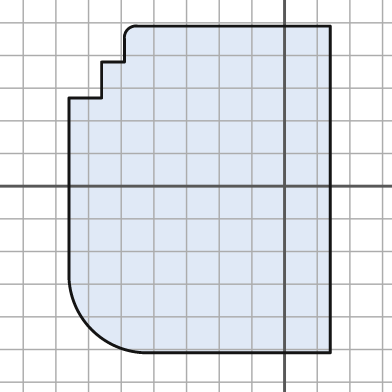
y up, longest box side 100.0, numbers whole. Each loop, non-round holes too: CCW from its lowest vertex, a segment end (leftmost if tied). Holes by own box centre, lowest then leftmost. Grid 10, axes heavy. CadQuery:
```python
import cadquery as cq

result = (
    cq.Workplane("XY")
    .moveTo(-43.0, -51.0)
    .lineTo(14.0, -51.0)
    .lineTo(14.0, 49.0)
    .lineTo(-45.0, 49.0)
    .threePointArc((-48.0, 48.0), (-49.0, 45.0))
    .lineTo(-49.0, 38.0)
    .lineTo(-56.0, 38.0)
    .lineTo(-56.0, 27.0)
    .lineTo(-66.0, 27.0)
    .lineTo(-66.0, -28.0)
    .threePointArc((-59.0, -44.0), (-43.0, -51.0))
    .close()
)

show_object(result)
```